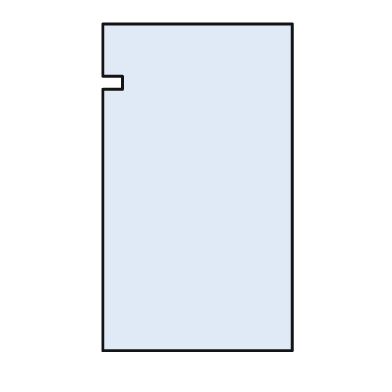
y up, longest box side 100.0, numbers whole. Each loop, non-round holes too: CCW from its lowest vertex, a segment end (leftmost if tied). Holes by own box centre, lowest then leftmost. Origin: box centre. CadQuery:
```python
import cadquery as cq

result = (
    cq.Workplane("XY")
    .moveTo(-29.0, -50.0)
    .lineTo(29.0, -50.0)
    .lineTo(29.0, 50.0)
    .lineTo(-29.0, 50.0)
    .lineTo(-29.0, 34.0)
    .lineTo(-23.0, 34.0)
    .lineTo(-23.0, 30.0)
    .lineTo(-29.0, 30.0)
    .close()
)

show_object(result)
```